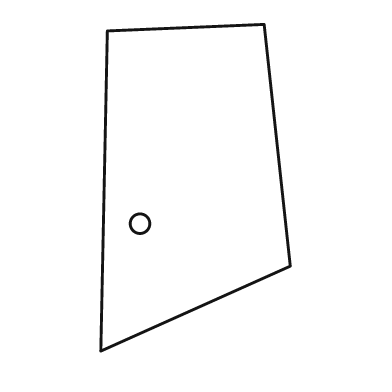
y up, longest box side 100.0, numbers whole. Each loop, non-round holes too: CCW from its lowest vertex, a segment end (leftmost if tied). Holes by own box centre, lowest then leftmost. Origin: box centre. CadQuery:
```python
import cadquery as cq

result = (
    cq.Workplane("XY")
    .moveTo(-29.0, -50.0)
    .lineTo(29.0, -24.0)
    .lineTo(21.0, 50.0)
    .lineTo(-27.0, 48.0)
    .close()
    .moveTo(-17.0, -11.0)
    .circle(3.0)
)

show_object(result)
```